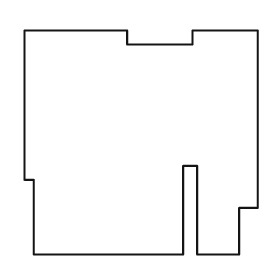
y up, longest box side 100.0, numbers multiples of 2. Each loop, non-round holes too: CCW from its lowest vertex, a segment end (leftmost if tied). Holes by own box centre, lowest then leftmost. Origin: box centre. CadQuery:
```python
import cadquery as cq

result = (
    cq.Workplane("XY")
    .moveTo(-46.0, -48.0)
    .lineTo(18.0, -48.0)
    .lineTo(18.0, -10.0)
    .lineTo(24.0, -10.0)
    .lineTo(24.0, -48.0)
    .lineTo(42.0, -48.0)
    .lineTo(42.0, -28.0)
    .lineTo(50.0, -28.0)
    .lineTo(50.0, 48.0)
    .lineTo(22.0, 48.0)
    .lineTo(22.0, 42.0)
    .lineTo(-6.0, 42.0)
    .lineTo(-6.0, 48.0)
    .lineTo(-50.0, 48.0)
    .lineTo(-50.0, -16.0)
    .lineTo(-46.0, -16.0)
    .close()
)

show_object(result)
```